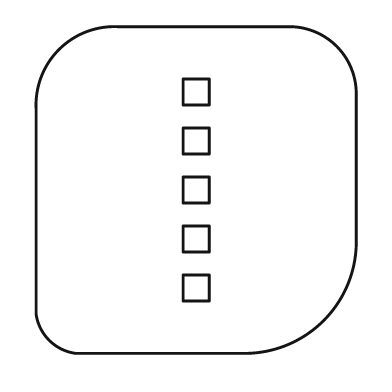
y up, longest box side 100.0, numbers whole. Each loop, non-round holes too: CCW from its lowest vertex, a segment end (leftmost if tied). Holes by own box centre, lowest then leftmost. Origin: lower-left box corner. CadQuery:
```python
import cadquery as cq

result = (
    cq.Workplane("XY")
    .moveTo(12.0, 0.0)
    .lineTo(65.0, 0.0)
    .threePointArc((88.0, 10.0), (98.0, 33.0))
    .lineTo(98.0, 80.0)
    .threePointArc((92.0, 94.0), (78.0, 100.0))
    .lineTo(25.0, 100.0)
    .threePointArc((7.0, 93.0), (0.0, 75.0))
    .lineTo(0.0, 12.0)
    .threePointArc((4.0, 4.0), (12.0, 0.0))
    .close()
    .moveTo(45.0, 16.0)
    .lineTo(53.0, 16.0)
    .lineTo(53.0, 24.0)
    .lineTo(45.0, 24.0)
    .close()
    .moveTo(45.0, 31.0)
    .lineTo(53.0, 31.0)
    .lineTo(53.0, 39.0)
    .lineTo(45.0, 39.0)
    .close()
    .moveTo(45.0, 46.0)
    .lineTo(53.0, 46.0)
    .lineTo(53.0, 54.0)
    .lineTo(45.0, 54.0)
    .close()
    .moveTo(45.0, 61.0)
    .lineTo(53.0, 61.0)
    .lineTo(53.0, 69.0)
    .lineTo(45.0, 69.0)
    .close()
    .moveTo(45.0, 76.0)
    .lineTo(53.0, 76.0)
    .lineTo(53.0, 84.0)
    .lineTo(45.0, 84.0)
    .close()
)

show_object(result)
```